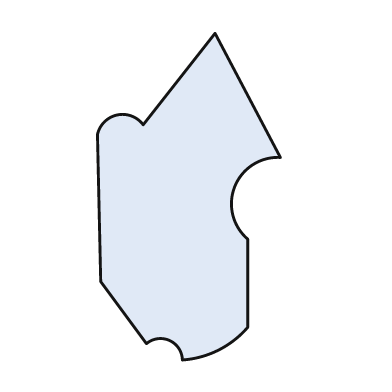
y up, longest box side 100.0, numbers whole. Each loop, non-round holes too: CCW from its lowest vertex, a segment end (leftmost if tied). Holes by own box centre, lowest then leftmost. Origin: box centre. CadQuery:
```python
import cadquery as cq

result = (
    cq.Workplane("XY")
    .moveTo(-2.0, -50.0)
    .threePointArc((9.0, -47.0), (18.0, -40.0))
    .lineTo(18.0, -13.0)
    .threePointArc((14.0, 3.0), (28.0, 12.0))
    .lineTo(8.0, 50.0)
    .lineTo(-14.0, 22.0)
    .threePointArc((-22.0, 25.0), (-28.0, 19.0))
    .lineTo(-27.0, -26.0)
    .lineTo(-13.0, -45.0)
    .threePointArc((-6.0, -44.0), (-2.0, -50.0))
    .close()
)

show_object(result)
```